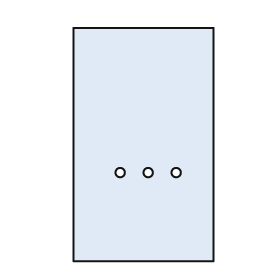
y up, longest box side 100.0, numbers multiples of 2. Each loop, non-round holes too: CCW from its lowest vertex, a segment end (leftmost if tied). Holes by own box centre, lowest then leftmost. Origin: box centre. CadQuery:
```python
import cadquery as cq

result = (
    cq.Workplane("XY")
    .moveTo(-30.0, -50.0)
    .lineTo(30.0, -50.0)
    .lineTo(30.0, 50.0)
    .lineTo(-30.0, 50.0)
    .close()
    .moveTo(-10.0, -12.0)
    .circle(2.0)
    .moveTo(2.0, -12.0)
    .circle(2.0)
    .moveTo(14.0, -12.0)
    .circle(2.0)
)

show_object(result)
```